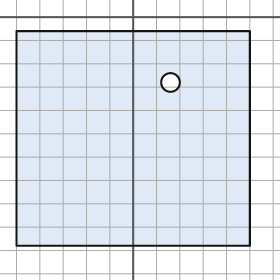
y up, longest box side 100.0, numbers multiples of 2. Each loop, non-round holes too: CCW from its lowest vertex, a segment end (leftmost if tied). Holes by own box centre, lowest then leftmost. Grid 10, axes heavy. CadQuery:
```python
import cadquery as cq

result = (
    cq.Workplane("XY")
    .moveTo(-50.0, -98.0)
    .lineTo(50.0, -98.0)
    .lineTo(50.0, -6.0)
    .lineTo(-50.0, -6.0)
    .close()
    .moveTo(16.0, -28.0)
    .circle(4.0)
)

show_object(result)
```